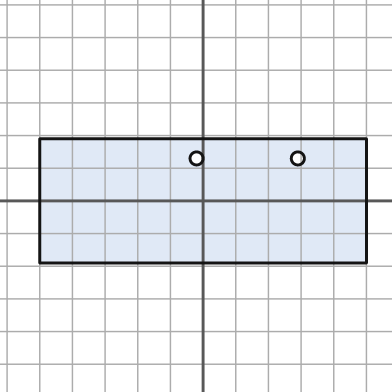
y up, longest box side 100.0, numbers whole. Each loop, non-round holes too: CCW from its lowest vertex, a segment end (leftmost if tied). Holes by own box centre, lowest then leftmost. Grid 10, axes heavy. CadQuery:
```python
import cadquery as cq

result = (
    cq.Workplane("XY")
    .moveTo(-50.0, -19.0)
    .lineTo(50.0, -19.0)
    .lineTo(50.0, 19.0)
    .lineTo(-50.0, 19.0)
    .close()
    .moveTo(-2.0, 13.0)
    .circle(2.0)
    .moveTo(29.0, 13.0)
    .circle(2.0)
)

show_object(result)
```